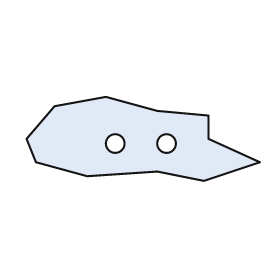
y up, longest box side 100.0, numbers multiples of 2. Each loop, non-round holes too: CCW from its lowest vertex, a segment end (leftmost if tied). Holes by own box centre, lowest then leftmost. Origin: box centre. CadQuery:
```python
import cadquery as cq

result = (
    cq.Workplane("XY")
    .moveTo(26.0, -18.0)
    .lineTo(50.0, -10.0)
    .lineTo(28.0, 0.0)
    .lineTo(28.0, 10.0)
    .lineTo(6.0, 12.0)
    .lineTo(-16.0, 18.0)
    .lineTo(-38.0, 14.0)
    .lineTo(-50.0, 0.0)
    .lineTo(-46.0, -10.0)
    .lineTo(-24.0, -16.0)
    .lineTo(6.0, -14.0)
    .close()
    .moveTo(-12.0, -2.0)
    .circle(4.0)
    .moveTo(10.0, -2.0)
    .circle(4.0)
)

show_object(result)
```